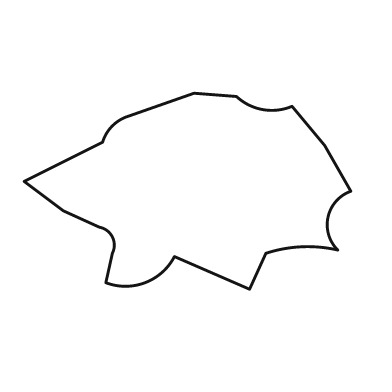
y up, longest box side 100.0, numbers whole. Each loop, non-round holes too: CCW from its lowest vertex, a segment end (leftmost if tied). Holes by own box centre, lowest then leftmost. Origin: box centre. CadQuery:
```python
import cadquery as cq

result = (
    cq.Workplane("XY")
    .moveTo(19.0, -30.0)
    .lineTo(24.0, -19.0)
    .threePointArc((35.0, -17.0), (46.0, -18.0))
    .threePointArc((43.0, -8.0), (50.0, 0.0))
    .lineTo(42.0, 14.0)
    .lineTo(32.0, 26.0)
    .threePointArc((23.0, 25.0), (15.0, 29.0))
    .lineTo(2.0, 30.0)
    .lineTo(-18.0, 23.0)
    .threePointArc((-23.0, 20.0), (-26.0, 15.0))
    .lineTo(-50.0, 3.0)
    .lineTo(-38.0, -6.0)
    .lineTo(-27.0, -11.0)
    .threePointArc((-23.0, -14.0), (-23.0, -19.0))
    .lineTo(-25.0, -28.0)
    .threePointArc((-13.0, -28.0), (-4.0, -20.0))
    .close()
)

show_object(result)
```